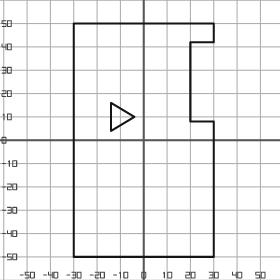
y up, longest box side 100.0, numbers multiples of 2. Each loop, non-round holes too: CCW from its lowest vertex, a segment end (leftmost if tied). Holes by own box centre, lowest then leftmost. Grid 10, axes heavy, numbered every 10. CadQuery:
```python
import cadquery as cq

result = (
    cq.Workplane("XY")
    .moveTo(-30.0, -50.0)
    .lineTo(30.0, -50.0)
    .lineTo(30.0, 8.0)
    .lineTo(20.0, 8.0)
    .lineTo(20.0, 42.0)
    .lineTo(30.0, 42.0)
    .lineTo(30.0, 50.0)
    .lineTo(-30.0, 50.0)
    .close()
    .moveTo(-14.0, 4.0)
    .lineTo(-4.0, 10.0)
    .lineTo(-14.0, 16.0)
    .close()
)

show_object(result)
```